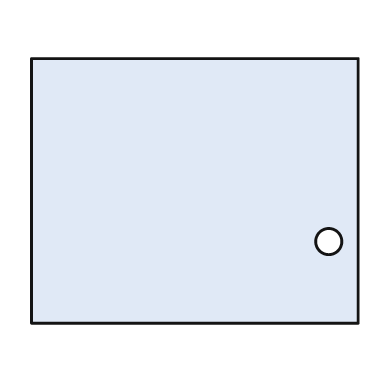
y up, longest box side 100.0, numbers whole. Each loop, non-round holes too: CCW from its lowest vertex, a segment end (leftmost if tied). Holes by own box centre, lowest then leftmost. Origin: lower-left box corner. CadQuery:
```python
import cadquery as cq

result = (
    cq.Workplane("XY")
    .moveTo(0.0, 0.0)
    .lineTo(100.0, 0.0)
    .lineTo(100.0, 81.0)
    .lineTo(0.0, 81.0)
    .close()
    .moveTo(91.0, 25.0)
    .circle(4.0)
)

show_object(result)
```